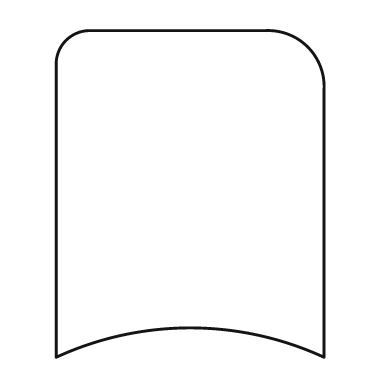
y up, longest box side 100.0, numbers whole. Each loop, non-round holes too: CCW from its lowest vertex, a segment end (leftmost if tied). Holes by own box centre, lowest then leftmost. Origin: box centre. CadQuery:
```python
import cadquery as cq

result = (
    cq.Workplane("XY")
    .moveTo(-41.0, -50.0)
    .threePointArc((0.0, -41.0), (41.0, -50.0))
    .lineTo(41.0, 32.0)
    .threePointArc((36.0, 45.0), (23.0, 50.0))
    .lineTo(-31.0, 50.0)
    .threePointArc((-38.0, 47.0), (-41.0, 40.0))
    .close()
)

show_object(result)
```